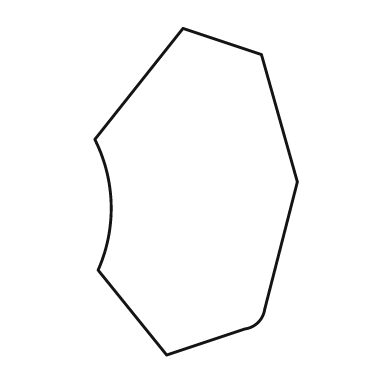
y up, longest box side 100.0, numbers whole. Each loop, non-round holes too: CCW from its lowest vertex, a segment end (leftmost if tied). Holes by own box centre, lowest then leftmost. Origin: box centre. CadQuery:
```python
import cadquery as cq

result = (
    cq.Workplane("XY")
    .moveTo(-9.0, -50.0)
    .lineTo(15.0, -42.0)
    .threePointArc((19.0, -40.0), (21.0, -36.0))
    .lineTo(31.0, 3.0)
    .lineTo(20.0, 42.0)
    .lineTo(-4.0, 50.0)
    .lineTo(-31.0, 16.0)
    .threePointArc((-26.0, -4.0), (-30.0, -24.0))
    .close()
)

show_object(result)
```